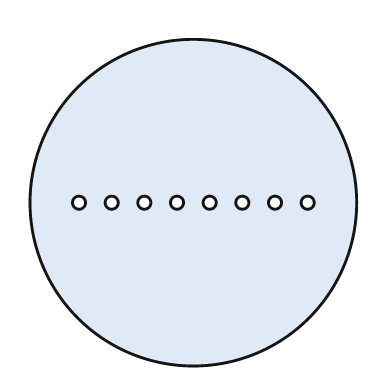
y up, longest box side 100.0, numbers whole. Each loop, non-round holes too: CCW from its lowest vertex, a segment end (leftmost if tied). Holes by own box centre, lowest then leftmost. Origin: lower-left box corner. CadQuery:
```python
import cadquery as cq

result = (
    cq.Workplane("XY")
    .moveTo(50.0, 50.0)
    .circle(50.0)
    .moveTo(15.0, 50.0)
    .circle(2.0)
    .moveTo(25.0, 50.0)
    .circle(2.0)
    .moveTo(35.0, 50.0)
    .circle(2.0)
    .moveTo(45.0, 50.0)
    .circle(2.0)
    .moveTo(55.0, 50.0)
    .circle(2.0)
    .moveTo(65.0, 50.0)
    .circle(2.0)
    .moveTo(75.0, 50.0)
    .circle(2.0)
    .moveTo(85.0, 50.0)
    .circle(2.0)
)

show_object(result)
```